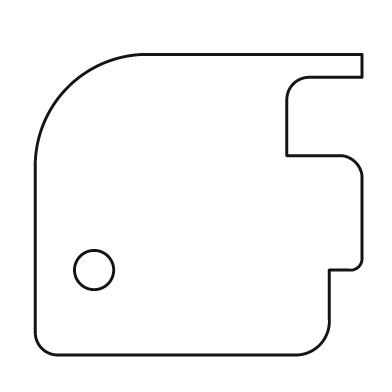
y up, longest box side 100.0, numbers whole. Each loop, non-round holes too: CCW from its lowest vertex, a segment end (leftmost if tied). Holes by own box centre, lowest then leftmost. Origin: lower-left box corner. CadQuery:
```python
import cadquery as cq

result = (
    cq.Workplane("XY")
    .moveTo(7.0, 0.0)
    .lineTo(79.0, 0.0)
    .threePointArc((87.0, 3.0), (90.0, 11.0))
    .lineTo(90.0, 26.0)
    .lineTo(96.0, 26.0)
    .threePointArc((99.0, 27.0), (100.0, 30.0))
    .lineTo(100.0, 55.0)
    .threePointArc((98.0, 59.0), (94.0, 61.0))
    .lineTo(77.0, 61.0)
    .lineTo(77.0, 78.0)
    .threePointArc((79.0, 83.0), (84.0, 85.0))
    .lineTo(100.0, 85.0)
    .lineTo(100.0, 92.0)
    .lineTo(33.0, 92.0)
    .threePointArc((10.0, 82.0), (0.0, 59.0))
    .lineTo(0.0, 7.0)
    .threePointArc((2.0, 2.0), (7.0, 0.0))
    .close()
    .moveTo(18.0, 26.0)
    .circle(6.0)
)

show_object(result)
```